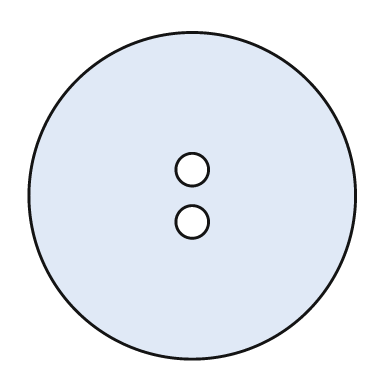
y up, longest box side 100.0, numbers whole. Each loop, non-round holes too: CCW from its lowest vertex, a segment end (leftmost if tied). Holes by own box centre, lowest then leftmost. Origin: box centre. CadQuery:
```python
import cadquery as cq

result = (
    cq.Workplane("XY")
    .moveTo(0.0, 0.0)
    .circle(50.0)
    .moveTo(0.0, -8.0)
    .circle(5.0)
    .moveTo(0.0, 8.0)
    .circle(5.0)
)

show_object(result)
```